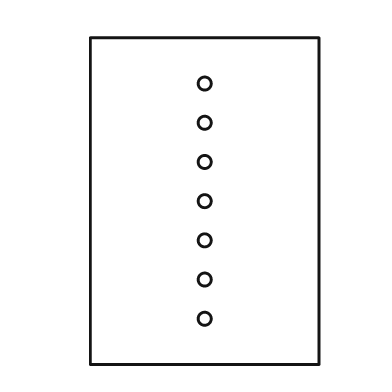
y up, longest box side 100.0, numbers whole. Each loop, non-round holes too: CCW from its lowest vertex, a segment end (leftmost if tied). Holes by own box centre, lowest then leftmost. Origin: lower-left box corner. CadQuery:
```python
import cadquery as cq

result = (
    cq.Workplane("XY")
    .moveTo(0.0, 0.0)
    .lineTo(70.0, 0.0)
    .lineTo(70.0, 100.0)
    .lineTo(0.0, 100.0)
    .close()
    .moveTo(35.0, 14.0)
    .circle(2.0)
    .moveTo(35.0, 26.0)
    .circle(2.0)
    .moveTo(35.0, 38.0)
    .circle(2.0)
    .moveTo(35.0, 50.0)
    .circle(2.0)
    .moveTo(35.0, 62.0)
    .circle(2.0)
    .moveTo(35.0, 74.0)
    .circle(2.0)
    .moveTo(35.0, 86.0)
    .circle(2.0)
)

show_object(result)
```